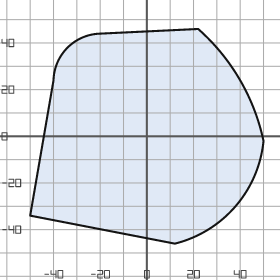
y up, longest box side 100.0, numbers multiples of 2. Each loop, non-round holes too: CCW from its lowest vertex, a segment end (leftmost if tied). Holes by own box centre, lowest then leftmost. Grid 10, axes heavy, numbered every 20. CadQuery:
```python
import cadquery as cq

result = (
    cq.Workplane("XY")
    .moveTo(12.0, -46.0)
    .threePointArc((38.0, -30.0), (50.0, -2.0))
    .threePointArc((40.0, 24.0), (22.0, 46.0))
    .lineTo(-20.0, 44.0)
    .threePointArc((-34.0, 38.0), (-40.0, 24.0))
    .lineTo(-50.0, -34.0)
    .close()
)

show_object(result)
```